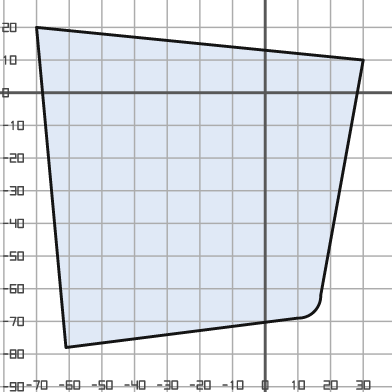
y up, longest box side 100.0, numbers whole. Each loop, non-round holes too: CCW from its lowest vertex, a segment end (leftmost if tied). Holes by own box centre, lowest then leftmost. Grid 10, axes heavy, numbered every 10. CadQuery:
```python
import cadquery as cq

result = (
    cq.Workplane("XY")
    .moveTo(-61.0, -78.0)
    .lineTo(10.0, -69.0)
    .threePointArc((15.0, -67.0), (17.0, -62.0))
    .lineTo(30.0, 10.0)
    .lineTo(-70.0, 20.0)
    .close()
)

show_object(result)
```